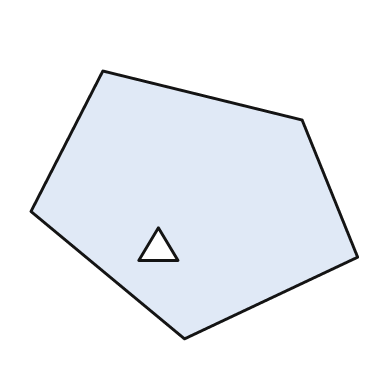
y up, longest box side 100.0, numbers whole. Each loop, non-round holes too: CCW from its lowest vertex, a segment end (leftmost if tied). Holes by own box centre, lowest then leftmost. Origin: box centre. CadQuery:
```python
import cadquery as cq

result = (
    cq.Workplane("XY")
    .moveTo(-3.0, -41.0)
    .lineTo(50.0, -16.0)
    .lineTo(33.0, 26.0)
    .lineTo(-28.0, 41.0)
    .lineTo(-50.0, -2.0)
    .close()
    .moveTo(-17.0, -17.0)
    .lineTo(-5.0, -17.0)
    .lineTo(-11.0, -7.0)
    .close()
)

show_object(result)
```